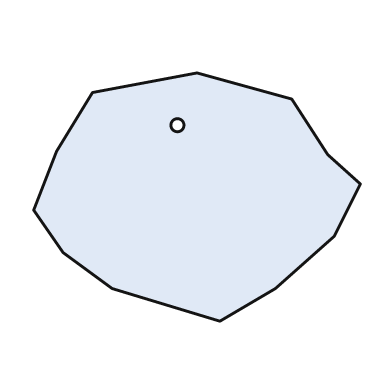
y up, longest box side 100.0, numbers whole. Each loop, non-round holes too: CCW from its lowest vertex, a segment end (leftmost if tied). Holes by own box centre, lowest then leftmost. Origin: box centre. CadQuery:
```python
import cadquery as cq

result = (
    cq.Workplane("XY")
    .moveTo(7.0, -38.0)
    .lineTo(24.0, -28.0)
    .lineTo(42.0, -12.0)
    .lineTo(50.0, 4.0)
    .lineTo(40.0, 13.0)
    .lineTo(29.0, 30.0)
    .lineTo(0.0, 38.0)
    .lineTo(-32.0, 32.0)
    .lineTo(-43.0, 14.0)
    .lineTo(-50.0, -4.0)
    .lineTo(-41.0, -17.0)
    .lineTo(-26.0, -28.0)
    .close()
    .moveTo(-6.0, 22.0)
    .circle(2.0)
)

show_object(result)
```